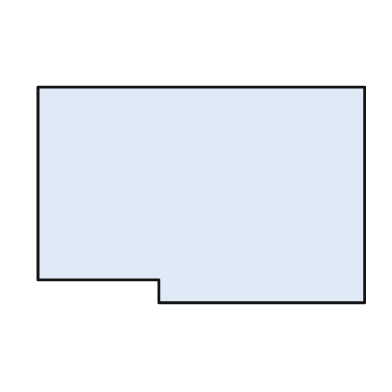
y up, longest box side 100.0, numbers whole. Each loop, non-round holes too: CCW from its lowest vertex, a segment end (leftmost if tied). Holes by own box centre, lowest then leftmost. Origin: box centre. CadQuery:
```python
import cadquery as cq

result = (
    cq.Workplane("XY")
    .moveTo(-13.0, -33.0)
    .lineTo(50.0, -33.0)
    .lineTo(50.0, 33.0)
    .lineTo(-50.0, 33.0)
    .lineTo(-50.0, -26.0)
    .lineTo(-13.0, -26.0)
    .close()
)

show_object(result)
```